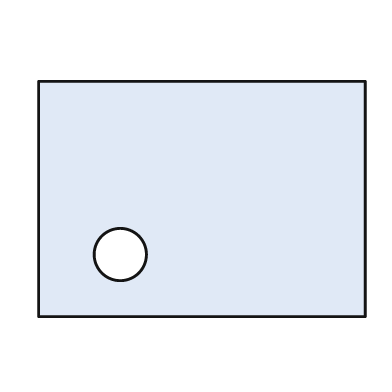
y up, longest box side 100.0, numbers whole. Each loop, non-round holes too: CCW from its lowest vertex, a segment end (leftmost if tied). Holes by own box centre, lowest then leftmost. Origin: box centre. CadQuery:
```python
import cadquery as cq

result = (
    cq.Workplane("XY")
    .moveTo(-50.0, -36.0)
    .lineTo(50.0, -36.0)
    .lineTo(50.0, 36.0)
    .lineTo(-50.0, 36.0)
    .close()
    .moveTo(-25.0, -17.0)
    .circle(8.0)
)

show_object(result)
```